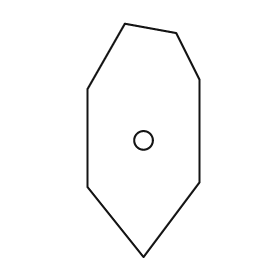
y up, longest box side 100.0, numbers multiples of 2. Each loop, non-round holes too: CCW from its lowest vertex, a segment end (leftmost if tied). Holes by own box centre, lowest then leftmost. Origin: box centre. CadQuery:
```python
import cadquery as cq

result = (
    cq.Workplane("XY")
    .moveTo(0.0, -50.0)
    .lineTo(24.0, -18.0)
    .lineTo(24.0, 26.0)
    .lineTo(14.0, 46.0)
    .lineTo(-8.0, 50.0)
    .lineTo(-24.0, 22.0)
    .lineTo(-24.0, -20.0)
    .close()
    .moveTo(0.0, 0.0)
    .circle(4.0)
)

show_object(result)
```